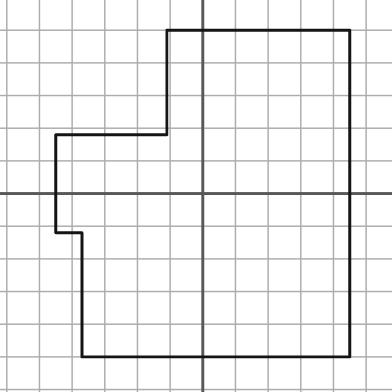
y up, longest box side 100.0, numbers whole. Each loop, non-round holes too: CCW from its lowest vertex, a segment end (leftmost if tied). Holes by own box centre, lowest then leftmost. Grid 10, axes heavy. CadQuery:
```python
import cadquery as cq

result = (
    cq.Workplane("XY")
    .moveTo(-37.0, -50.0)
    .lineTo(45.0, -50.0)
    .lineTo(45.0, 50.0)
    .lineTo(-11.0, 50.0)
    .lineTo(-11.0, 18.0)
    .lineTo(-45.0, 18.0)
    .lineTo(-45.0, -12.0)
    .lineTo(-37.0, -12.0)
    .close()
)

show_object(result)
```